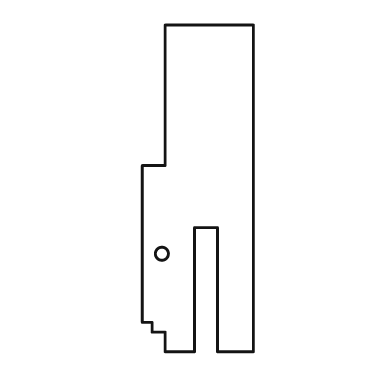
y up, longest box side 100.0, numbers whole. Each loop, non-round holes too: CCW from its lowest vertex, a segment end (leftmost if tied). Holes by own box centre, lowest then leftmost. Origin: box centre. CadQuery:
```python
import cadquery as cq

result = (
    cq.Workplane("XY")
    .moveTo(-10.0, -50.0)
    .lineTo(-1.0, -50.0)
    .lineTo(-1.0, -12.0)
    .lineTo(6.0, -12.0)
    .lineTo(6.0, -50.0)
    .lineTo(17.0, -50.0)
    .lineTo(17.0, 50.0)
    .lineTo(-10.0, 50.0)
    .lineTo(-10.0, 7.0)
    .lineTo(-17.0, 7.0)
    .lineTo(-17.0, -41.0)
    .lineTo(-14.0, -41.0)
    .lineTo(-14.0, -44.0)
    .lineTo(-10.0, -44.0)
    .close()
    .moveTo(-11.0, -20.0)
    .circle(2.0)
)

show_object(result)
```